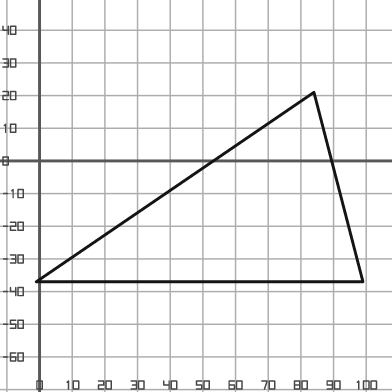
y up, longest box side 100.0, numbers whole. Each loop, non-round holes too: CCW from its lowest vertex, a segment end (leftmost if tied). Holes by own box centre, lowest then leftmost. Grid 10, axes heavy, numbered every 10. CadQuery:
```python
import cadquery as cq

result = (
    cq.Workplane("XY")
    .moveTo(-1.0, -37.0)
    .lineTo(99.0, -37.0)
    .lineTo(84.0, 21.0)
    .close()
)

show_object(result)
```